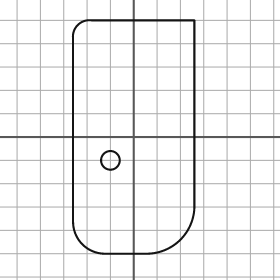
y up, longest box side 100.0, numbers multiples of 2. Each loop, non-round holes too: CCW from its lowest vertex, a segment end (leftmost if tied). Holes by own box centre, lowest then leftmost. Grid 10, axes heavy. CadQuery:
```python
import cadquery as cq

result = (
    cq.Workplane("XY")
    .moveTo(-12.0, -50.0)
    .lineTo(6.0, -50.0)
    .threePointArc((20.0, -44.0), (26.0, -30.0))
    .lineTo(26.0, 50.0)
    .lineTo(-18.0, 50.0)
    .threePointArc((-24.0, 48.0), (-26.0, 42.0))
    .lineTo(-26.0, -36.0)
    .threePointArc((-22.0, -46.0), (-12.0, -50.0))
    .close()
    .moveTo(-10.0, -10.0)
    .circle(4.0)
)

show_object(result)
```